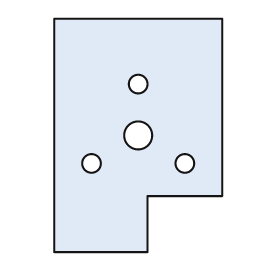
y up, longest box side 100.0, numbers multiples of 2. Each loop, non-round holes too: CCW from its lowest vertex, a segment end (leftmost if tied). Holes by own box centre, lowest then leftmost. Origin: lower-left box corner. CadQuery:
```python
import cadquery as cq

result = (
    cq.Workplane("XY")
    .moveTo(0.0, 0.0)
    .lineTo(40.0, 0.0)
    .lineTo(40.0, 24.0)
    .lineTo(72.0, 24.0)
    .lineTo(72.0, 100.0)
    .lineTo(0.0, 100.0)
    .close()
    .moveTo(16.0, 38.0)
    .circle(4.0)
    .moveTo(56.0, 38.0)
    .circle(4.0)
    .moveTo(36.0, 50.0)
    .circle(6.0)
    .moveTo(36.0, 72.0)
    .circle(4.0)
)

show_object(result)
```